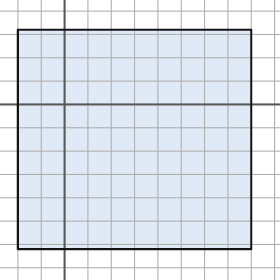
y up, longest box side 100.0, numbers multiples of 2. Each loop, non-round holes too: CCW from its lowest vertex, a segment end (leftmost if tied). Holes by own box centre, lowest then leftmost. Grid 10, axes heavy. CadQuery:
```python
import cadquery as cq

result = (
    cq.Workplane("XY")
    .moveTo(-20.0, -62.0)
    .lineTo(80.0, -62.0)
    .lineTo(80.0, 32.0)
    .lineTo(-20.0, 32.0)
    .close()
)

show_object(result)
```